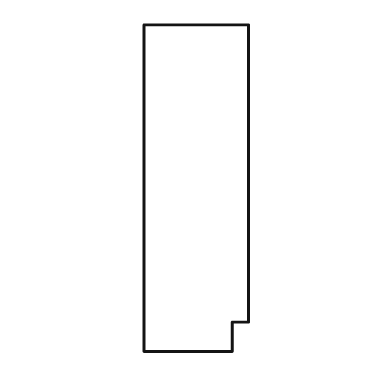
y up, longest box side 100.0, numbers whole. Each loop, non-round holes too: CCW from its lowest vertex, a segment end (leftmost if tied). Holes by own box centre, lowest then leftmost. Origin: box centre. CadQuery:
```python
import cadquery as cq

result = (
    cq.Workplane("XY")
    .moveTo(-16.0, -50.0)
    .lineTo(11.0, -50.0)
    .lineTo(11.0, -41.0)
    .lineTo(16.0, -41.0)
    .lineTo(16.0, 50.0)
    .lineTo(-16.0, 50.0)
    .close()
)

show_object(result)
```